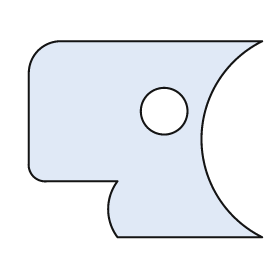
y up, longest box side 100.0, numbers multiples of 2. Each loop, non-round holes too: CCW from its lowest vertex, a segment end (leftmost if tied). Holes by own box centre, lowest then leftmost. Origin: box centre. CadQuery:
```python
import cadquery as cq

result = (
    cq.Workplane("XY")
    .moveTo(-12.0, -42.0)
    .lineTo(50.0, -42.0)
    .threePointArc((24.0, 0.0), (50.0, 42.0))
    .lineTo(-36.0, 42.0)
    .threePointArc((-46.0, 38.0), (-50.0, 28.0))
    .lineTo(-50.0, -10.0)
    .threePointArc((-48.0, -16.0), (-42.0, -18.0))
    .lineTo(-12.0, -18.0)
    .threePointArc((-16.0, -30.0), (-12.0, -42.0))
    .close()
    .moveTo(8.0, 12.0)
    .circle(10.0)
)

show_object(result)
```